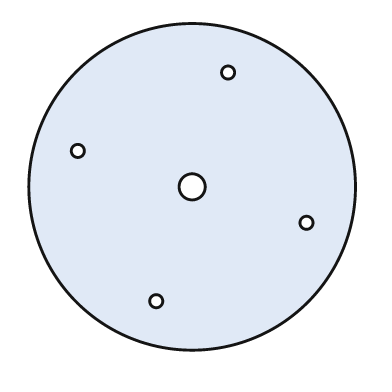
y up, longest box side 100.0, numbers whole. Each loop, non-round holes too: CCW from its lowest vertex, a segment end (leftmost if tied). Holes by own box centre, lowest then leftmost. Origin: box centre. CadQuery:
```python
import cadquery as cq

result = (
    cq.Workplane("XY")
    .moveTo(0.0, 0.0)
    .circle(50.0)
    .moveTo(-11.0, -35.0)
    .circle(2.0)
    .moveTo(35.0, -11.0)
    .circle(2.0)
    .moveTo(0.0, 0.0)
    .circle(4.0)
    .moveTo(-35.0, 11.0)
    .circle(2.0)
    .moveTo(11.0, 35.0)
    .circle(2.0)
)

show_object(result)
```